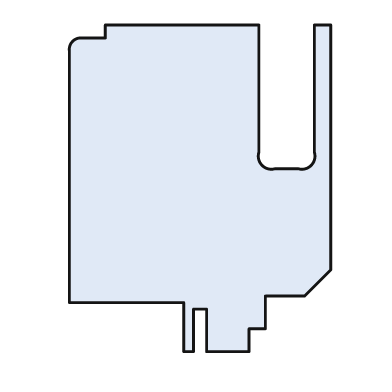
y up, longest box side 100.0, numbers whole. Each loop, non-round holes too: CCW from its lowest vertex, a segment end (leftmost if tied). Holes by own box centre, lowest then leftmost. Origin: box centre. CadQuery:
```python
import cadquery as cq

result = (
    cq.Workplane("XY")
    .moveTo(-5.0, -50.0)
    .lineTo(-2.0, -50.0)
    .lineTo(-2.0, -37.0)
    .lineTo(2.0, -37.0)
    .lineTo(2.0, -50.0)
    .lineTo(15.0, -50.0)
    .lineTo(15.0, -43.0)
    .lineTo(20.0, -43.0)
    .lineTo(20.0, -33.0)
    .lineTo(32.0, -33.0)
    .lineTo(40.0, -25.0)
    .lineTo(40.0, 50.0)
    .lineTo(35.0, 50.0)
    .lineTo(35.0, 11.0)
    .threePointArc((34.0, 7.0), (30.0, 6.0))
    .lineTo(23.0, 6.0)
    .threePointArc((19.0, 7.0), (18.0, 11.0))
    .lineTo(18.0, 50.0)
    .lineTo(-29.0, 50.0)
    .lineTo(-29.0, 46.0)
    .lineTo(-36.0, 46.0)
    .threePointArc((-39.0, 45.0), (-40.0, 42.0))
    .lineTo(-40.0, -35.0)
    .lineTo(-5.0, -35.0)
    .close()
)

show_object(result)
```